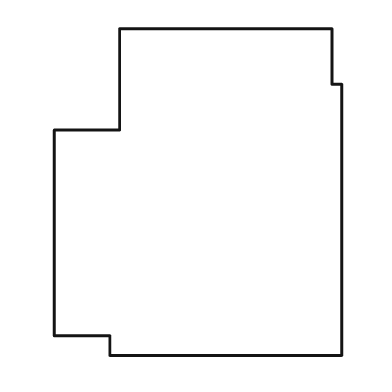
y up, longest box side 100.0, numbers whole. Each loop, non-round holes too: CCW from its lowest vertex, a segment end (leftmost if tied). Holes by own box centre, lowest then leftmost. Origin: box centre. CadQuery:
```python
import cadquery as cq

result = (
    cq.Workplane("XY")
    .moveTo(-27.0, -50.0)
    .lineTo(44.0, -50.0)
    .lineTo(44.0, 33.0)
    .lineTo(41.0, 33.0)
    .lineTo(41.0, 50.0)
    .lineTo(-24.0, 50.0)
    .lineTo(-24.0, 19.0)
    .lineTo(-44.0, 19.0)
    .lineTo(-44.0, -44.0)
    .lineTo(-27.0, -44.0)
    .close()
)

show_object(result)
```